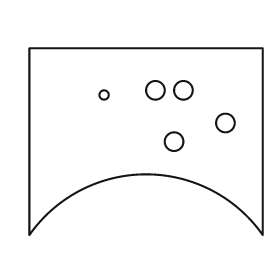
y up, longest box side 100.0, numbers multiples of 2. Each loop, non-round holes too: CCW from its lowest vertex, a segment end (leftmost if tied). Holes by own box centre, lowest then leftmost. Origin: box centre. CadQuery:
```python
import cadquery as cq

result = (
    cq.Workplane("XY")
    .moveTo(-50.0, -40.0)
    .threePointArc((0.0, -14.0), (50.0, -40.0))
    .lineTo(50.0, 40.0)
    .lineTo(-50.0, 40.0)
    .close()
    .moveTo(12.0, 0.0)
    .circle(4.0)
    .moveTo(34.0, 8.0)
    .circle(4.0)
    .moveTo(-18.0, 20.0)
    .circle(2.0)
    .moveTo(4.0, 22.0)
    .circle(4.0)
    .moveTo(16.0, 22.0)
    .circle(4.0)
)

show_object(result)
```